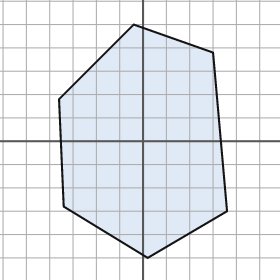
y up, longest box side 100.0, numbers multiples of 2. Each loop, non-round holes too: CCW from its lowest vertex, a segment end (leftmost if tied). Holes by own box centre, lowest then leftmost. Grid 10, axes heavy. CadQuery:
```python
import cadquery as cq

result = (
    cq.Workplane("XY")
    .moveTo(2.0, -50.0)
    .lineTo(36.0, -30.0)
    .lineTo(30.0, 38.0)
    .lineTo(-4.0, 50.0)
    .lineTo(-36.0, 18.0)
    .lineTo(-34.0, -28.0)
    .close()
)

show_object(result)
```